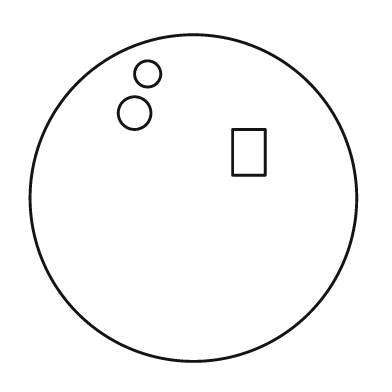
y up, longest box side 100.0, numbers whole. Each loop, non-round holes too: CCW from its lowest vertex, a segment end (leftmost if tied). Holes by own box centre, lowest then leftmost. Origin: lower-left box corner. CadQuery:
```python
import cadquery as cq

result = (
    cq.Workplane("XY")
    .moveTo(50.0, 50.0)
    .circle(50.0)
    .moveTo(62.0, 57.0)
    .lineTo(72.0, 57.0)
    .lineTo(72.0, 71.0)
    .lineTo(62.0, 71.0)
    .close()
    .moveTo(32.0, 76.0)
    .circle(5.0)
    .moveTo(36.0, 88.0)
    .circle(4.0)
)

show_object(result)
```